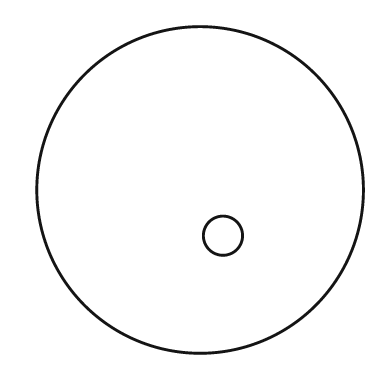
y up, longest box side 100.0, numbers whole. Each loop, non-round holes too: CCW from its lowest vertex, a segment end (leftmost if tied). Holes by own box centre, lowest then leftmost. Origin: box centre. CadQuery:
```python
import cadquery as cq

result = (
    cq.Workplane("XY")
    .moveTo(0.0, 0.0)
    .circle(50.0)
    .moveTo(7.0, -14.0)
    .circle(6.0)
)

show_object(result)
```